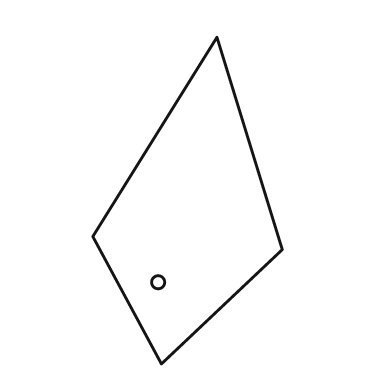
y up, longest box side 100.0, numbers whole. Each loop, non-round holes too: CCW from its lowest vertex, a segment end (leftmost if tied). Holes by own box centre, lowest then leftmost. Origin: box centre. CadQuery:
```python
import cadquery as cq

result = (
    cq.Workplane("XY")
    .moveTo(-8.0, -50.0)
    .lineTo(29.0, -15.0)
    .lineTo(9.0, 50.0)
    .lineTo(-29.0, -11.0)
    .close()
    .moveTo(-9.0, -25.0)
    .circle(2.0)
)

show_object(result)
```